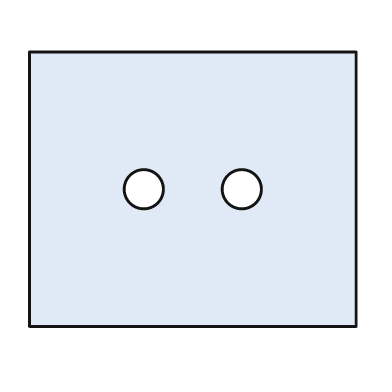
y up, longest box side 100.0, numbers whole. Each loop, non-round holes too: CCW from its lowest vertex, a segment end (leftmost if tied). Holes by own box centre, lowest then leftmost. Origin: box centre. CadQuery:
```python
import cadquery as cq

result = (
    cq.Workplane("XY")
    .moveTo(-50.0, -42.0)
    .lineTo(50.0, -42.0)
    .lineTo(50.0, 42.0)
    .lineTo(-50.0, 42.0)
    .close()
    .moveTo(-15.0, 0.0)
    .circle(6.0)
    .moveTo(15.0, 0.0)
    .circle(6.0)
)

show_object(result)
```